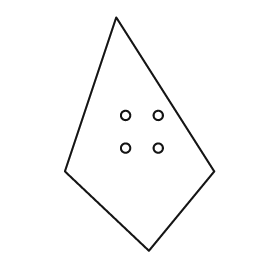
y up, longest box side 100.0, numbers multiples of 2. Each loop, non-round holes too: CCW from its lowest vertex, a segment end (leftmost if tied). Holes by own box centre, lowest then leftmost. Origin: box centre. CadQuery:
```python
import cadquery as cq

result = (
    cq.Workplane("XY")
    .moveTo(4.0, -50.0)
    .lineTo(32.0, -16.0)
    .lineTo(-10.0, 50.0)
    .lineTo(-32.0, -16.0)
    .close()
    .moveTo(-6.0, -6.0)
    .circle(2.0)
    .moveTo(8.0, -6.0)
    .circle(2.0)
    .moveTo(-6.0, 8.0)
    .circle(2.0)
    .moveTo(8.0, 8.0)
    .circle(2.0)
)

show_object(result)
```